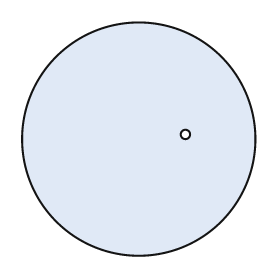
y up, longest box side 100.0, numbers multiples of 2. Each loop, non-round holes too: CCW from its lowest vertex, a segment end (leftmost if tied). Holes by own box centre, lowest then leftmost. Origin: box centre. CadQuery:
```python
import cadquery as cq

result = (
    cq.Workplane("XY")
    .moveTo(0.0, 0.0)
    .circle(50.0)
    .moveTo(20.0, 2.0)
    .circle(2.0)
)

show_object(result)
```